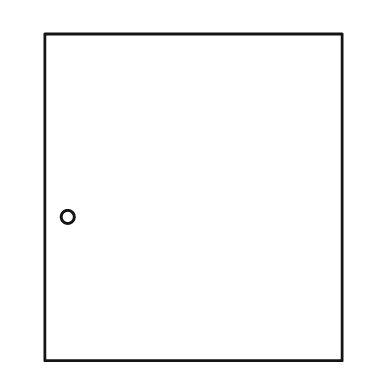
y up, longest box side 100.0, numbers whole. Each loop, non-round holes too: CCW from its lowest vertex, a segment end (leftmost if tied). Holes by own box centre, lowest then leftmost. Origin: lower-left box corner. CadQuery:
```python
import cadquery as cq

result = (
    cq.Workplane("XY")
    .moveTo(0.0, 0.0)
    .lineTo(91.0, 0.0)
    .lineTo(91.0, 100.0)
    .lineTo(0.0, 100.0)
    .close()
    .moveTo(7.0, 44.0)
    .circle(2.0)
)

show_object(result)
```